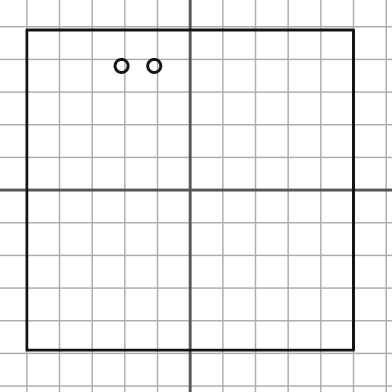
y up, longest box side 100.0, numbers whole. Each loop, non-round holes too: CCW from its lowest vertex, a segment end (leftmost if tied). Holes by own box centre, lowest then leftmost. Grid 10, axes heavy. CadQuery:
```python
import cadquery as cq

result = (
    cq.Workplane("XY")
    .moveTo(-50.0, -49.0)
    .lineTo(50.0, -49.0)
    .lineTo(50.0, 49.0)
    .lineTo(-50.0, 49.0)
    .close()
    .moveTo(-21.0, 38.0)
    .circle(2.0)
    .moveTo(-11.0, 38.0)
    .circle(2.0)
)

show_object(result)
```